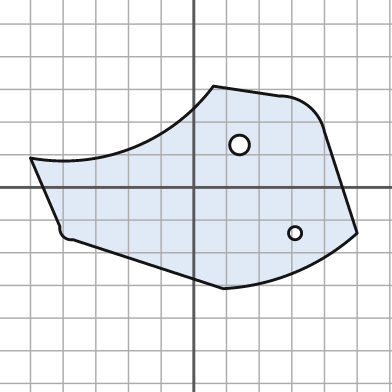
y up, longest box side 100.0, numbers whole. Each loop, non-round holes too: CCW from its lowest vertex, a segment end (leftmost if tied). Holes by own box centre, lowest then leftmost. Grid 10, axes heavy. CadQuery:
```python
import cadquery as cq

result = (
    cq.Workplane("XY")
    .moveTo(9.0, -31.0)
    .threePointArc((31.0, -26.0), (50.0, -14.0))
    .lineTo(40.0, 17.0)
    .threePointArc((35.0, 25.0), (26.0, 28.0))
    .lineTo(6.0, 31.0)
    .threePointArc((-19.0, 12.0), (-50.0, 9.0))
    .lineTo(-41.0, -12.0)
    .threePointArc((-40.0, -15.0), (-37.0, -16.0))
    .close()
    .moveTo(31.0, -14.0)
    .circle(2.0)
    .moveTo(14.0, 13.0)
    .circle(3.0)
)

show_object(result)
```